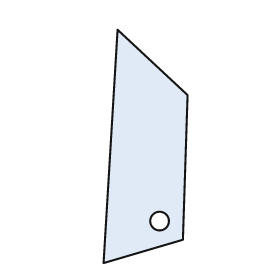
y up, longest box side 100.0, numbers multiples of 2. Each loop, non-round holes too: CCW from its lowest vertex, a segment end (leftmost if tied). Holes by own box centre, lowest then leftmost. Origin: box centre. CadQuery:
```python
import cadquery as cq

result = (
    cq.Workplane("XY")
    .moveTo(-18.0, -50.0)
    .lineTo(16.0, -40.0)
    .lineTo(18.0, 22.0)
    .lineTo(-12.0, 50.0)
    .close()
    .moveTo(6.0, -32.0)
    .circle(4.0)
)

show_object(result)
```